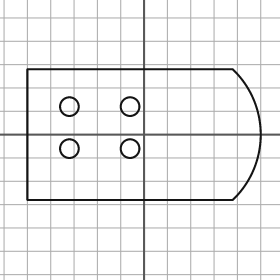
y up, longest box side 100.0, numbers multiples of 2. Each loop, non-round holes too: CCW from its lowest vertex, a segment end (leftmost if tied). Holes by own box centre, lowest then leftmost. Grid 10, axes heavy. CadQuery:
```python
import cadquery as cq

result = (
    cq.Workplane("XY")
    .moveTo(-50.0, -28.0)
    .lineTo(38.0, -28.0)
    .threePointArc((50.0, 0.0), (38.0, 28.0))
    .lineTo(-50.0, 28.0)
    .close()
    .moveTo(-32.0, -6.0)
    .circle(4.0)
    .moveTo(-6.0, -6.0)
    .circle(4.0)
    .moveTo(-32.0, 12.0)
    .circle(4.0)
    .moveTo(-6.0, 12.0)
    .circle(4.0)
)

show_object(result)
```